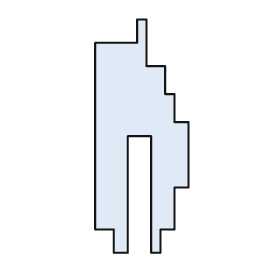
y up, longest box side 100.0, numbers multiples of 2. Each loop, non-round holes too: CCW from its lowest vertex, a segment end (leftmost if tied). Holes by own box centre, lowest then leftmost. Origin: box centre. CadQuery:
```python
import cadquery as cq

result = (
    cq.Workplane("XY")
    .moveTo(-12.0, -50.0)
    .lineTo(-6.0, -50.0)
    .lineTo(-6.0, 0.0)
    .lineTo(4.0, 0.0)
    .lineTo(4.0, -50.0)
    .lineTo(8.0, -50.0)
    .lineTo(8.0, -40.0)
    .lineTo(14.0, -40.0)
    .lineTo(14.0, -22.0)
    .lineTo(20.0, -22.0)
    .lineTo(20.0, 6.0)
    .lineTo(14.0, 6.0)
    .lineTo(14.0, 18.0)
    .lineTo(10.0, 18.0)
    .lineTo(10.0, 30.0)
    .lineTo(2.0, 30.0)
    .lineTo(2.0, 50.0)
    .lineTo(-2.0, 50.0)
    .lineTo(-2.0, 40.0)
    .lineTo(-20.0, 40.0)
    .lineTo(-20.0, -40.0)
    .lineTo(-12.0, -40.0)
    .close()
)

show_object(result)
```